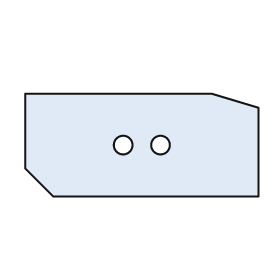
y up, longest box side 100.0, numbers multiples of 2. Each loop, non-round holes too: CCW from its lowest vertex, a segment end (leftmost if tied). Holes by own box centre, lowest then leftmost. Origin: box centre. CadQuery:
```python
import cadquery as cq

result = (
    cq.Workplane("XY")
    .moveTo(-38.0, -22.0)
    .lineTo(50.0, -22.0)
    .lineTo(50.0, 16.0)
    .lineTo(30.0, 22.0)
    .lineTo(-50.0, 22.0)
    .lineTo(-50.0, -10.0)
    .close()
    .moveTo(-8.0, 0.0)
    .circle(4.0)
    .moveTo(8.0, 0.0)
    .circle(4.0)
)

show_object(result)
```